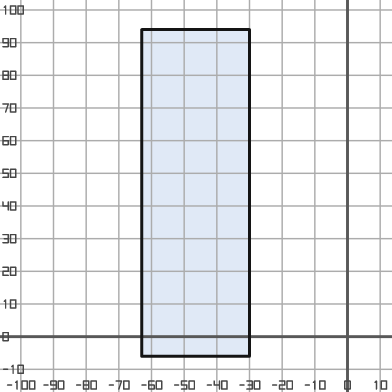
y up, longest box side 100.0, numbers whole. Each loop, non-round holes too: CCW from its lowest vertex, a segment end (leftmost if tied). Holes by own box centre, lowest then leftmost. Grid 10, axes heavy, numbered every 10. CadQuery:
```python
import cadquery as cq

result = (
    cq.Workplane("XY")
    .moveTo(-63.0, -6.0)
    .lineTo(-30.0, -6.0)
    .lineTo(-30.0, 94.0)
    .lineTo(-63.0, 94.0)
    .close()
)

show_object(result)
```